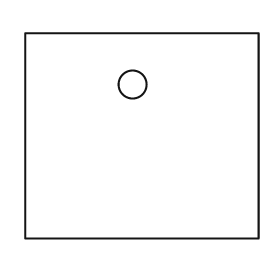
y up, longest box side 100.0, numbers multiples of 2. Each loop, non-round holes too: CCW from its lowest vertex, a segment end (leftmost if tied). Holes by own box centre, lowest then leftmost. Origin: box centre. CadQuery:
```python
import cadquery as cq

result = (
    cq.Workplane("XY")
    .moveTo(-50.0, -44.0)
    .lineTo(50.0, -44.0)
    .lineTo(50.0, 44.0)
    .lineTo(-50.0, 44.0)
    .close()
    .moveTo(-4.0, 22.0)
    .circle(6.0)
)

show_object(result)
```